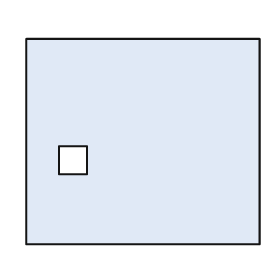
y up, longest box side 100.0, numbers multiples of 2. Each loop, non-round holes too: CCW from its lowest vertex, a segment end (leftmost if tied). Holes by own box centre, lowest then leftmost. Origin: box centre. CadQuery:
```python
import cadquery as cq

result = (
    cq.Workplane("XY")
    .moveTo(-50.0, -44.0)
    .lineTo(50.0, -44.0)
    .lineTo(50.0, 44.0)
    .lineTo(-50.0, 44.0)
    .close()
    .moveTo(-36.0, -14.0)
    .lineTo(-24.0, -14.0)
    .lineTo(-24.0, -2.0)
    .lineTo(-36.0, -2.0)
    .close()
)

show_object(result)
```